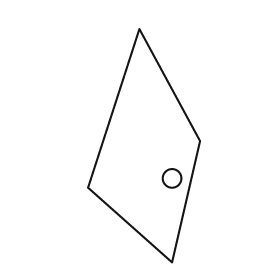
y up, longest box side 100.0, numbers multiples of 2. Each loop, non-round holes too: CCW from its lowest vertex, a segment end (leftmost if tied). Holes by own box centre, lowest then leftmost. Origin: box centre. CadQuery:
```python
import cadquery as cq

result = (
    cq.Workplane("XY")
    .moveTo(12.0, -50.0)
    .lineTo(24.0, 2.0)
    .lineTo(-2.0, 50.0)
    .lineTo(-24.0, -18.0)
    .close()
    .moveTo(12.0, -14.0)
    .circle(4.0)
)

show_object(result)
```